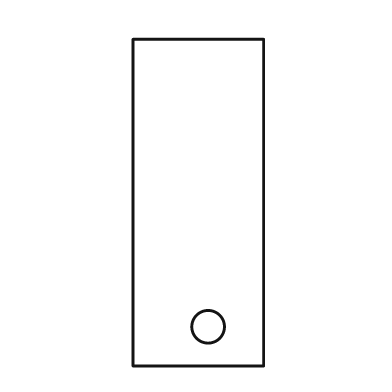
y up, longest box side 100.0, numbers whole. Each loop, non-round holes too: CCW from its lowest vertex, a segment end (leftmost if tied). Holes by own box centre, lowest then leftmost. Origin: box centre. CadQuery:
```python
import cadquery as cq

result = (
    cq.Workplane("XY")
    .moveTo(-20.0, -50.0)
    .lineTo(20.0, -50.0)
    .lineTo(20.0, 50.0)
    .lineTo(-20.0, 50.0)
    .close()
    .moveTo(3.0, -38.0)
    .circle(5.0)
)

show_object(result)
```